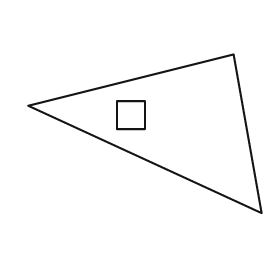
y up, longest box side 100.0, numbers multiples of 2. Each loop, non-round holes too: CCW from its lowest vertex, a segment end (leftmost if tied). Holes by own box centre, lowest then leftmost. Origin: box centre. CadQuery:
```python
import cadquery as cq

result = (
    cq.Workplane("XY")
    .moveTo(50.0, -34.0)
    .lineTo(38.0, 34.0)
    .lineTo(-50.0, 12.0)
    .close()
    .moveTo(-12.0, 2.0)
    .lineTo(0.0, 2.0)
    .lineTo(0.0, 14.0)
    .lineTo(-12.0, 14.0)
    .close()
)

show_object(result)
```